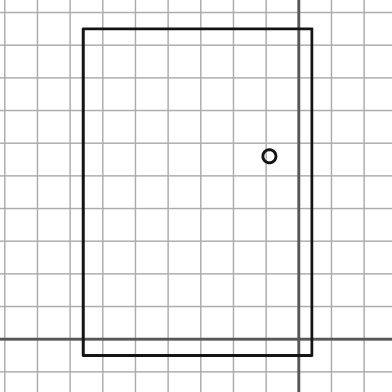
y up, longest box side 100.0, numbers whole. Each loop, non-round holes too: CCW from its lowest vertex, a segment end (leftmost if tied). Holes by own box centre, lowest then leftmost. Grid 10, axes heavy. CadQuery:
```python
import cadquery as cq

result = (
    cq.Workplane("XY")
    .moveTo(-66.0, -5.0)
    .lineTo(4.0, -5.0)
    .lineTo(4.0, 95.0)
    .lineTo(-66.0, 95.0)
    .close()
    .moveTo(-9.0, 56.0)
    .circle(2.0)
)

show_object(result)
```